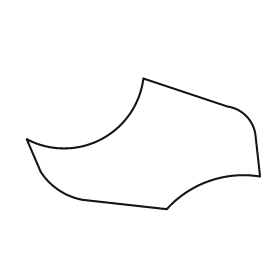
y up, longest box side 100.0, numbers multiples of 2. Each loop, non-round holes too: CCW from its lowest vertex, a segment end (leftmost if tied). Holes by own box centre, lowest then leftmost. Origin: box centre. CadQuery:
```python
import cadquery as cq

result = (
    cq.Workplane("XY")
    .moveTo(10.0, -28.0)
    .threePointArc((28.0, -16.0), (50.0, -14.0))
    .lineTo(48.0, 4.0)
    .threePointArc((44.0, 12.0), (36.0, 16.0))
    .lineTo(0.0, 28.0)
    .threePointArc((-18.0, 2.0), (-50.0, 2.0))
    .lineTo(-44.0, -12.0)
    .threePointArc((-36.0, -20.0), (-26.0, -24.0))
    .close()
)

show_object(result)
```